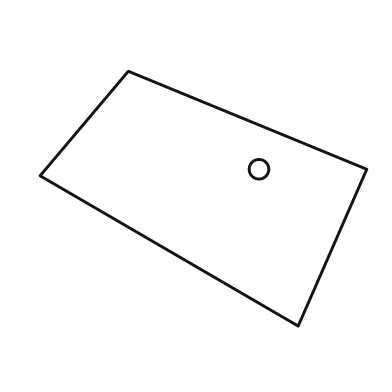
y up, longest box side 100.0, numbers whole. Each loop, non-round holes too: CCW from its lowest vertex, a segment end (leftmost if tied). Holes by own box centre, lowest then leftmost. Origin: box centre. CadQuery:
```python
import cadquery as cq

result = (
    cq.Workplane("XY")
    .moveTo(29.0, -39.0)
    .lineTo(50.0, 9.0)
    .lineTo(-23.0, 39.0)
    .lineTo(-50.0, 7.0)
    .close()
    .moveTo(17.0, 9.0)
    .circle(3.0)
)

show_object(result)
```